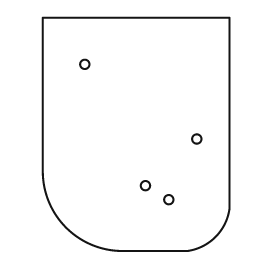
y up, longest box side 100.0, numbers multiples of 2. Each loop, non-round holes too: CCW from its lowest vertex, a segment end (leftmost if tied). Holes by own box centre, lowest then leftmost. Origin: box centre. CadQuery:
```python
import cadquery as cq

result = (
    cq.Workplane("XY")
    .moveTo(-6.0, -50.0)
    .lineTo(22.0, -50.0)
    .threePointArc((34.0, -44.0), (40.0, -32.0))
    .lineTo(40.0, 50.0)
    .lineTo(-40.0, 50.0)
    .lineTo(-40.0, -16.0)
    .threePointArc((-30.0, -40.0), (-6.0, -50.0))
    .close()
    .moveTo(14.0, -28.0)
    .circle(2.0)
    .moveTo(4.0, -22.0)
    .circle(2.0)
    .moveTo(26.0, -2.0)
    .circle(2.0)
    .moveTo(-22.0, 30.0)
    .circle(2.0)
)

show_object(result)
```